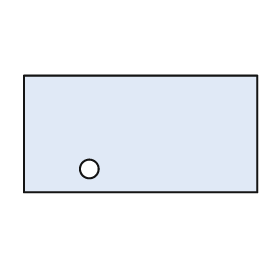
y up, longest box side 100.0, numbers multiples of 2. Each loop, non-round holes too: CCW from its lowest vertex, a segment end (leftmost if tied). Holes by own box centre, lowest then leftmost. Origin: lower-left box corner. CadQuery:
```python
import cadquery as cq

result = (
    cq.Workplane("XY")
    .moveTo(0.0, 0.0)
    .lineTo(100.0, 0.0)
    .lineTo(100.0, 50.0)
    .lineTo(0.0, 50.0)
    .close()
    .moveTo(28.0, 10.0)
    .circle(4.0)
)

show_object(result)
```